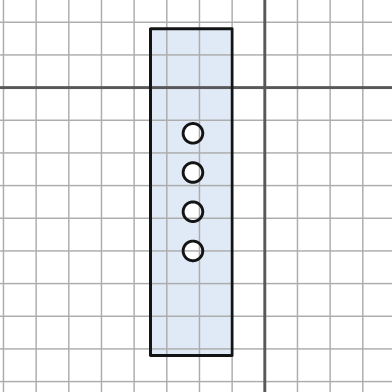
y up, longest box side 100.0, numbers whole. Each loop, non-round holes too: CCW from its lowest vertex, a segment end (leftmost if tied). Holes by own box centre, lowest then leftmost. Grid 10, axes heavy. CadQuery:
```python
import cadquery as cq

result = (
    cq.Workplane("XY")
    .moveTo(-35.0, -82.0)
    .lineTo(-10.0, -82.0)
    .lineTo(-10.0, 18.0)
    .lineTo(-35.0, 18.0)
    .close()
    .moveTo(-22.0, -50.0)
    .circle(3.0)
    .moveTo(-22.0, -38.0)
    .circle(3.0)
    .moveTo(-22.0, -26.0)
    .circle(3.0)
    .moveTo(-22.0, -14.0)
    .circle(3.0)
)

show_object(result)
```